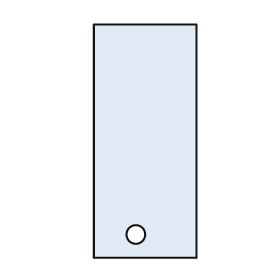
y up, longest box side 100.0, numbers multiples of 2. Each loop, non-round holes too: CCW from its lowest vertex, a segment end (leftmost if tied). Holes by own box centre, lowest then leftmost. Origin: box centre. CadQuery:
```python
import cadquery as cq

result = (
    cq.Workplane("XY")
    .moveTo(-22.0, -50.0)
    .lineTo(22.0, -50.0)
    .lineTo(22.0, 50.0)
    .lineTo(-22.0, 50.0)
    .close()
    .moveTo(-4.0, -40.0)
    .circle(4.0)
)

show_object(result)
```